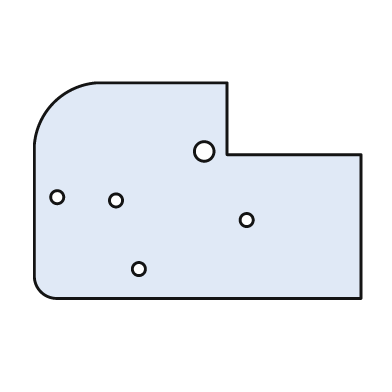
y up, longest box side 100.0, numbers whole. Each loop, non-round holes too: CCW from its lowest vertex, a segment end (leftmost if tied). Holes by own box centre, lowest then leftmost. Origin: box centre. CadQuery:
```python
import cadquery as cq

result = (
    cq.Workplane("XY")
    .moveTo(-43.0, -33.0)
    .lineTo(50.0, -33.0)
    .lineTo(50.0, 11.0)
    .lineTo(9.0, 11.0)
    .lineTo(9.0, 33.0)
    .lineTo(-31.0, 33.0)
    .threePointArc((-44.0, 27.0), (-50.0, 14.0))
    .lineTo(-50.0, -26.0)
    .threePointArc((-48.0, -31.0), (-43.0, -33.0))
    .close()
    .moveTo(-18.0, -24.0)
    .circle(2.0)
    .moveTo(15.0, -9.0)
    .circle(2.0)
    .moveTo(-25.0, -3.0)
    .circle(2.0)
    .moveTo(-43.0, -2.0)
    .circle(2.0)
    .moveTo(2.0, 12.0)
    .circle(3.0)
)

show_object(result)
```